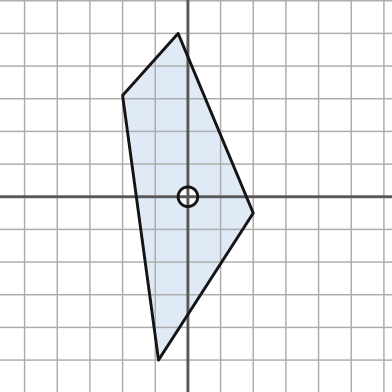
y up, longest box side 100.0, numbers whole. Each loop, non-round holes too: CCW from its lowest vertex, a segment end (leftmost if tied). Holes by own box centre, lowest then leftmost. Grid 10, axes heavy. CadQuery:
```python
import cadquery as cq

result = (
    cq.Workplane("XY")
    .moveTo(-9.0, -50.0)
    .lineTo(20.0, -5.0)
    .lineTo(-3.0, 50.0)
    .lineTo(-20.0, 31.0)
    .close()
    .moveTo(0.0, 0.0)
    .circle(3.0)
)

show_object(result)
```